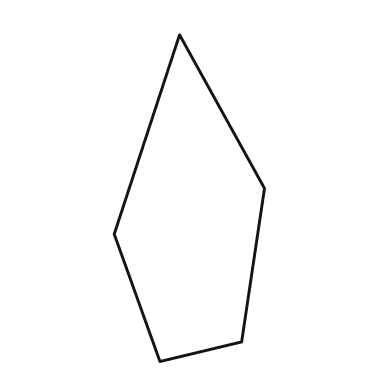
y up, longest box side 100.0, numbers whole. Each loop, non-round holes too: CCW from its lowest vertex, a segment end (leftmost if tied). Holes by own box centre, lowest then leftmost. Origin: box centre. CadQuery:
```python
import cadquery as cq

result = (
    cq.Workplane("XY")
    .moveTo(-9.0, -50.0)
    .lineTo(16.0, -44.0)
    .lineTo(23.0, 3.0)
    .lineTo(-3.0, 50.0)
    .lineTo(-23.0, -11.0)
    .close()
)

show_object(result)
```